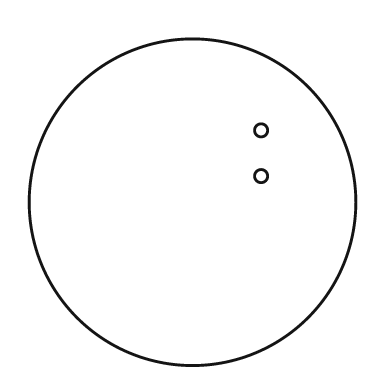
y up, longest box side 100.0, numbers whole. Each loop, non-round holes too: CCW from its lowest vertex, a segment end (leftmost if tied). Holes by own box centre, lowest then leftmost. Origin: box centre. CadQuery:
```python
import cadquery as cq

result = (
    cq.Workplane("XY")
    .moveTo(0.0, 0.0)
    .circle(50.0)
    .moveTo(21.0, 8.0)
    .circle(2.0)
    .moveTo(21.0, 22.0)
    .circle(2.0)
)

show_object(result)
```